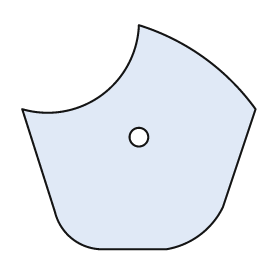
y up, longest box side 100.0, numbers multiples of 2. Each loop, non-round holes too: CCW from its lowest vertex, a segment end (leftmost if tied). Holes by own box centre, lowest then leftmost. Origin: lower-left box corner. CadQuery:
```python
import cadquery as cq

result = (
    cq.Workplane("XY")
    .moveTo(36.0, 0.0)
    .lineTo(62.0, 0.0)
    .threePointArc((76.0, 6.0), (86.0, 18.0))
    .lineTo(100.0, 60.0)
    .threePointArc((78.0, 82.0), (50.0, 96.0))
    .threePointArc((34.0, 66.0), (0.0, 60.0))
    .lineTo(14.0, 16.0)
    .threePointArc((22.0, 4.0), (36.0, 0.0))
    .close()
    .moveTo(50.0, 48.0)
    .circle(4.0)
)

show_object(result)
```